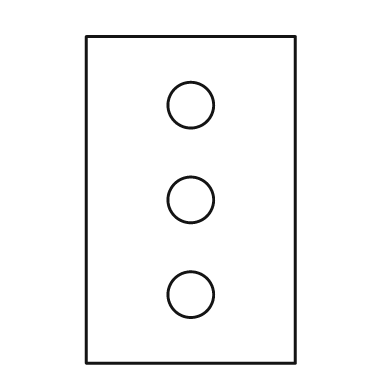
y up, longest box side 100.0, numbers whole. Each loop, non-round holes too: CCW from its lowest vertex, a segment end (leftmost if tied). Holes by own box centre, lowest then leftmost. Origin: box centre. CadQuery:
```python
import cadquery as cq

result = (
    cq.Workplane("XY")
    .moveTo(-32.0, -50.0)
    .lineTo(32.0, -50.0)
    .lineTo(32.0, 50.0)
    .lineTo(-32.0, 50.0)
    .close()
    .moveTo(0.0, -29.0)
    .circle(7.0)
    .moveTo(0.0, 0.0)
    .circle(7.0)
    .moveTo(0.0, 29.0)
    .circle(7.0)
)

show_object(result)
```